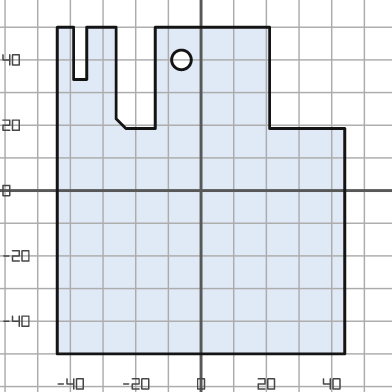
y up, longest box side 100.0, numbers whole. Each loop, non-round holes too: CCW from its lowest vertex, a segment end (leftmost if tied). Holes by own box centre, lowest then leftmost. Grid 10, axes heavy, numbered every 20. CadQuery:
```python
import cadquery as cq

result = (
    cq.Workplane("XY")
    .moveTo(-44.0, -50.0)
    .lineTo(44.0, -50.0)
    .lineTo(44.0, 19.0)
    .lineTo(21.0, 19.0)
    .lineTo(21.0, 50.0)
    .lineTo(-14.0, 50.0)
    .lineTo(-14.0, 19.0)
    .lineTo(-23.0, 19.0)
    .lineTo(-26.0, 22.0)
    .lineTo(-26.0, 50.0)
    .lineTo(-35.0, 50.0)
    .lineTo(-35.0, 34.0)
    .lineTo(-39.0, 34.0)
    .lineTo(-39.0, 50.0)
    .lineTo(-44.0, 50.0)
    .close()
    .moveTo(-6.0, 40.0)
    .circle(3.0)
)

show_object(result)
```